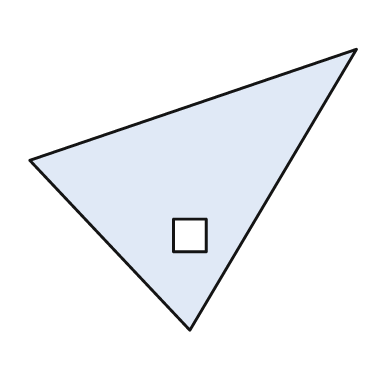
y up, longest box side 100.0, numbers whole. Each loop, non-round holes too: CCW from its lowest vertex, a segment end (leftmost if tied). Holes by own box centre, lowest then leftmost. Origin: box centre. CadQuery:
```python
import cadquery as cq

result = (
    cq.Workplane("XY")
    .moveTo(-1.0, -43.0)
    .lineTo(50.0, 43.0)
    .lineTo(-50.0, 9.0)
    .close()
    .moveTo(-6.0, -19.0)
    .lineTo(4.0, -19.0)
    .lineTo(4.0, -9.0)
    .lineTo(-6.0, -9.0)
    .close()
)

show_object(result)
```